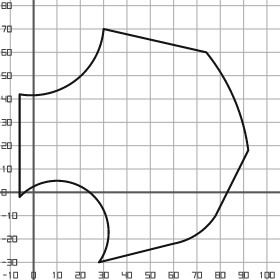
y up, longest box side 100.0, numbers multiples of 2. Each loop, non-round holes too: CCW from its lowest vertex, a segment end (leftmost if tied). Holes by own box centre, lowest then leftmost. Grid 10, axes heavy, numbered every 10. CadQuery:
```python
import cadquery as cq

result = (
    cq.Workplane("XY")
    .moveTo(28.0, -30.0)
    .lineTo(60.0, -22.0)
    .threePointArc((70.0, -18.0), (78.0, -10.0))
    .lineTo(92.0, 18.0)
    .threePointArc((86.0, 40.0), (74.0, 60.0))
    .lineTo(30.0, 70.0)
    .threePointArc((18.0, 48.0), (-6.0, 42.0))
    .lineTo(-6.0, -2.0)
    .threePointArc((24.0, 0.0), (28.0, -30.0))
    .close()
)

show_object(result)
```